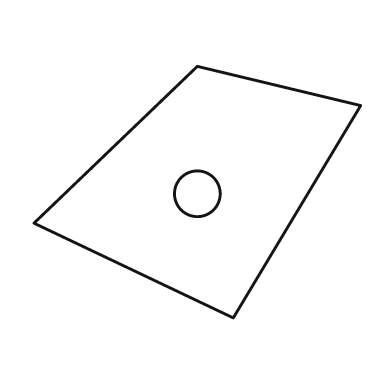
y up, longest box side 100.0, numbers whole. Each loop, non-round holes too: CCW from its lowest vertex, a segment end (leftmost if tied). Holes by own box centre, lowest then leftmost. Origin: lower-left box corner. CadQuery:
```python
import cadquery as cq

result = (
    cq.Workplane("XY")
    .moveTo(61.0, 0.0)
    .lineTo(100.0, 65.0)
    .lineTo(50.0, 77.0)
    .lineTo(0.0, 29.0)
    .close()
    .moveTo(50.0, 38.0)
    .circle(7.0)
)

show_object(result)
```